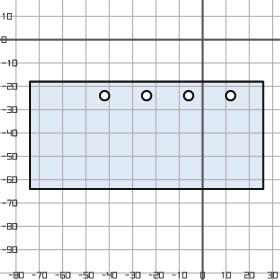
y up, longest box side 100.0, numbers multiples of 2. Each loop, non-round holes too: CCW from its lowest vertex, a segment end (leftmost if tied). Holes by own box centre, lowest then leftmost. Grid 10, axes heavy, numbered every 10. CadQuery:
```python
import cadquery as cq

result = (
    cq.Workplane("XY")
    .moveTo(-74.0, -64.0)
    .lineTo(26.0, -64.0)
    .lineTo(26.0, -18.0)
    .lineTo(-74.0, -18.0)
    .close()
    .moveTo(-42.0, -24.0)
    .circle(2.0)
    .moveTo(-24.0, -24.0)
    .circle(2.0)
    .moveTo(-6.0, -24.0)
    .circle(2.0)
    .moveTo(12.0, -24.0)
    .circle(2.0)
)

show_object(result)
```